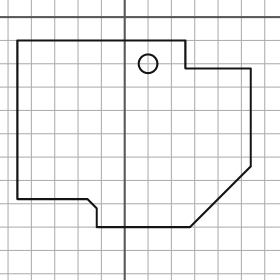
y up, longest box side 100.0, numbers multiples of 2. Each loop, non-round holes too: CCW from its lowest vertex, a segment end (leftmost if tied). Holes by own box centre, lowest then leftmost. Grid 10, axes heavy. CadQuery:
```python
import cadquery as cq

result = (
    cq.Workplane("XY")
    .moveTo(-12.0, -90.0)
    .lineTo(28.0, -90.0)
    .lineTo(54.0, -64.0)
    .lineTo(54.0, -22.0)
    .lineTo(26.0, -22.0)
    .lineTo(26.0, -10.0)
    .lineTo(-46.0, -10.0)
    .lineTo(-46.0, -78.0)
    .lineTo(-16.0, -78.0)
    .lineTo(-12.0, -82.0)
    .close()
    .moveTo(10.0, -20.0)
    .circle(4.0)
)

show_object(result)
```